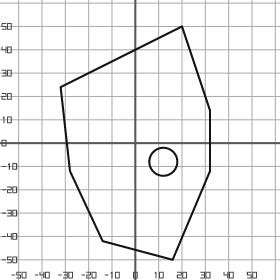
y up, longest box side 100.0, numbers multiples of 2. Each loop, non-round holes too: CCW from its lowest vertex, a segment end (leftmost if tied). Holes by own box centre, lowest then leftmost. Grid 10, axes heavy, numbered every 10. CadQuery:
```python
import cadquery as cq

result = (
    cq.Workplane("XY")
    .moveTo(16.0, -50.0)
    .lineTo(32.0, -12.0)
    .lineTo(32.0, 14.0)
    .lineTo(20.0, 50.0)
    .lineTo(-32.0, 24.0)
    .lineTo(-28.0, -12.0)
    .lineTo(-14.0, -42.0)
    .close()
    .moveTo(12.0, -8.0)
    .circle(6.0)
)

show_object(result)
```